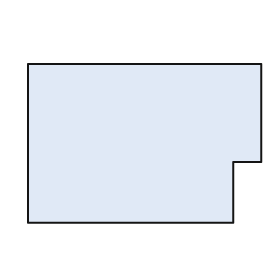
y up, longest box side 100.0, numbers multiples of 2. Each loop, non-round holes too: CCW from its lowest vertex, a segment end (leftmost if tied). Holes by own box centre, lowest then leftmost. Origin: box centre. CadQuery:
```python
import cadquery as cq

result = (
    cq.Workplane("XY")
    .moveTo(-50.0, -34.0)
    .lineTo(38.0, -34.0)
    .lineTo(38.0, -8.0)
    .lineTo(50.0, -8.0)
    .lineTo(50.0, 34.0)
    .lineTo(-50.0, 34.0)
    .close()
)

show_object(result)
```